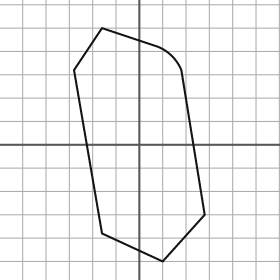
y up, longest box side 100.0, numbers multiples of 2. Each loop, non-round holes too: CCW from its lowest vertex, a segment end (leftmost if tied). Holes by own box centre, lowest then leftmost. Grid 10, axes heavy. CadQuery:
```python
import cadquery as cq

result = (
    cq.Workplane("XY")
    .moveTo(10.0, -50.0)
    .lineTo(28.0, -30.0)
    .lineTo(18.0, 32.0)
    .threePointArc((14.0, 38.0), (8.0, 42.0))
    .lineTo(-16.0, 50.0)
    .lineTo(-28.0, 32.0)
    .lineTo(-16.0, -38.0)
    .close()
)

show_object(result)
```